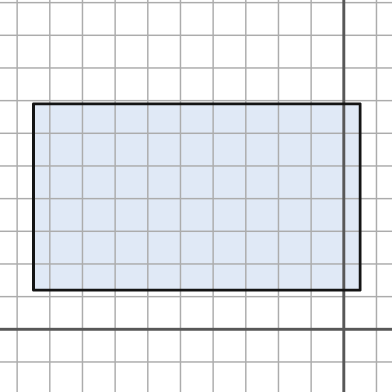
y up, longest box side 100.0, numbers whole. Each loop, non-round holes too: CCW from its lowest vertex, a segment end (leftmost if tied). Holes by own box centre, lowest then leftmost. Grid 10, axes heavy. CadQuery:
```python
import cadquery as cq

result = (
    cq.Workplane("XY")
    .moveTo(-95.0, 12.0)
    .lineTo(5.0, 12.0)
    .lineTo(5.0, 69.0)
    .lineTo(-95.0, 69.0)
    .close()
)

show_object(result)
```